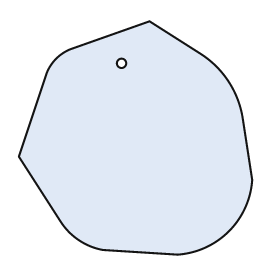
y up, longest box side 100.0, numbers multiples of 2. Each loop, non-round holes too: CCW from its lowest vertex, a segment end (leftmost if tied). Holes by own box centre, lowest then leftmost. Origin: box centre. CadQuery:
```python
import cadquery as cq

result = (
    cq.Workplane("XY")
    .moveTo(18.0, -50.0)
    .threePointArc((40.0, -40.0), (50.0, -18.0))
    .lineTo(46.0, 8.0)
    .threePointArc((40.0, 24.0), (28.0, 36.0))
    .lineTo(6.0, 50.0)
    .lineTo(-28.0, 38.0)
    .threePointArc((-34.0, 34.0), (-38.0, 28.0))
    .lineTo(-50.0, -8.0)
    .lineTo(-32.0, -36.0)
    .threePointArc((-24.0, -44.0), (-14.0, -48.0))
    .close()
    .moveTo(-6.0, 32.0)
    .circle(2.0)
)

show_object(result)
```